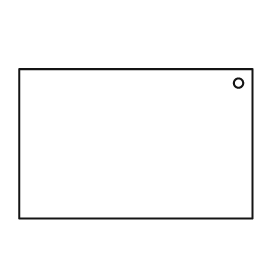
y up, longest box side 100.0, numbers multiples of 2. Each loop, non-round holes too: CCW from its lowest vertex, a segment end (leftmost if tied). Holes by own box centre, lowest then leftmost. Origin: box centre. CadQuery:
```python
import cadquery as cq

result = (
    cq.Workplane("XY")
    .moveTo(-50.0, -32.0)
    .lineTo(50.0, -32.0)
    .lineTo(50.0, 32.0)
    .lineTo(-50.0, 32.0)
    .close()
    .moveTo(44.0, 26.0)
    .circle(2.0)
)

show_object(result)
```